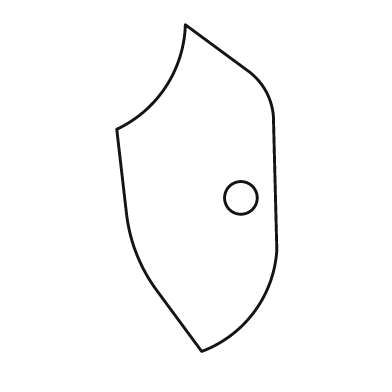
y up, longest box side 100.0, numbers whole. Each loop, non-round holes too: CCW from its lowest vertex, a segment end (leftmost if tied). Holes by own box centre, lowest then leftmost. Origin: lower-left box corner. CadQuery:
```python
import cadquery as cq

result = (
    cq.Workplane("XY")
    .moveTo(26.0, 0.0)
    .threePointArc((42.0, 12.0), (49.0, 31.0))
    .lineTo(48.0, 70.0)
    .threePointArc((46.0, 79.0), (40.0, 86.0))
    .lineTo(21.0, 100.0)
    .threePointArc((15.0, 81.0), (0.0, 68.0))
    .lineTo(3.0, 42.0)
    .threePointArc((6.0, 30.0), (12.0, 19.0))
    .close()
    .moveTo(38.0, 47.0)
    .circle(5.0)
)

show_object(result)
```